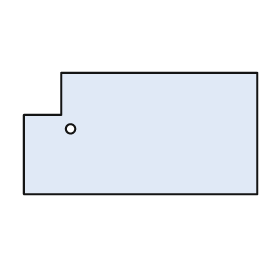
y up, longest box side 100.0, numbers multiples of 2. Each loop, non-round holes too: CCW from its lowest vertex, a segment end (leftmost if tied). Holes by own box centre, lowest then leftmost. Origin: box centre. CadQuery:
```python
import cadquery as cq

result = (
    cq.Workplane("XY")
    .moveTo(-50.0, -26.0)
    .lineTo(50.0, -26.0)
    .lineTo(50.0, 26.0)
    .lineTo(-34.0, 26.0)
    .lineTo(-34.0, 8.0)
    .lineTo(-50.0, 8.0)
    .close()
    .moveTo(-30.0, 2.0)
    .circle(2.0)
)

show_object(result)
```